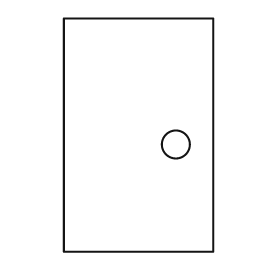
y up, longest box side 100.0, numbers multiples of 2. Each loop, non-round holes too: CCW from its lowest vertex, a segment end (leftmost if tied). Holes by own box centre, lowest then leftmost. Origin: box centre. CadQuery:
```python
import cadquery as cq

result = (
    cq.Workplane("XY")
    .moveTo(-32.0, -50.0)
    .lineTo(32.0, -50.0)
    .lineTo(32.0, 50.0)
    .lineTo(-32.0, 50.0)
    .close()
    .moveTo(16.0, -4.0)
    .circle(6.0)
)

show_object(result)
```